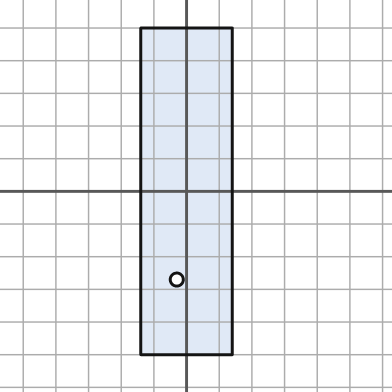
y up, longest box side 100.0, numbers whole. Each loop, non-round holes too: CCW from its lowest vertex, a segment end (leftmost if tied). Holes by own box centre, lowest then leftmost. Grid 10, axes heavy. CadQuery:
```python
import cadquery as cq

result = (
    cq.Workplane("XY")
    .moveTo(-14.0, -50.0)
    .lineTo(14.0, -50.0)
    .lineTo(14.0, 50.0)
    .lineTo(-14.0, 50.0)
    .close()
    .moveTo(-3.0, -27.0)
    .circle(2.0)
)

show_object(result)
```